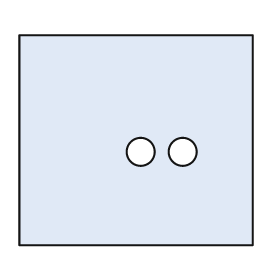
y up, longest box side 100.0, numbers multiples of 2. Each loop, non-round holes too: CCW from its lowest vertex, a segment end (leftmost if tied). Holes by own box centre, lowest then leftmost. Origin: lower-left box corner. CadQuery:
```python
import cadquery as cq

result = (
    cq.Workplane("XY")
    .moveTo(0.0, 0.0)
    .lineTo(100.0, 0.0)
    .lineTo(100.0, 90.0)
    .lineTo(0.0, 90.0)
    .close()
    .moveTo(52.0, 40.0)
    .circle(6.0)
    .moveTo(70.0, 40.0)
    .circle(6.0)
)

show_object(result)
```